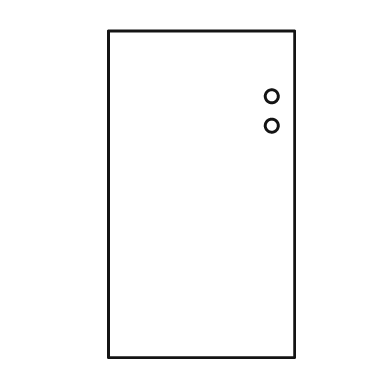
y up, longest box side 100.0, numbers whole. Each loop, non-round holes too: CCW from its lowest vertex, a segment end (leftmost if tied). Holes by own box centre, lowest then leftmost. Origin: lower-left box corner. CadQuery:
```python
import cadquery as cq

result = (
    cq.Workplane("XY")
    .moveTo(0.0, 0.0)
    .lineTo(57.0, 0.0)
    .lineTo(57.0, 100.0)
    .lineTo(0.0, 100.0)
    .close()
    .moveTo(50.0, 71.0)
    .circle(2.0)
    .moveTo(50.0, 80.0)
    .circle(2.0)
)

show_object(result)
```